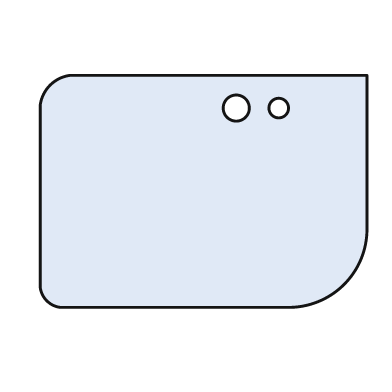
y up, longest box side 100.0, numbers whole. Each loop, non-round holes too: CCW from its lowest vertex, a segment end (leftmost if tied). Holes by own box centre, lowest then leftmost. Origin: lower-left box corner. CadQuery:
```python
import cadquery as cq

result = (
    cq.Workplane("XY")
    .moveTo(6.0, 0.0)
    .lineTo(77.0, 0.0)
    .threePointArc((93.0, 7.0), (100.0, 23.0))
    .lineTo(100.0, 71.0)
    .lineTo(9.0, 71.0)
    .threePointArc((3.0, 68.0), (0.0, 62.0))
    .lineTo(0.0, 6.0)
    .threePointArc((2.0, 2.0), (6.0, 0.0))
    .close()
    .moveTo(60.0, 61.0)
    .circle(4.0)
    .moveTo(73.0, 61.0)
    .circle(3.0)
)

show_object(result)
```